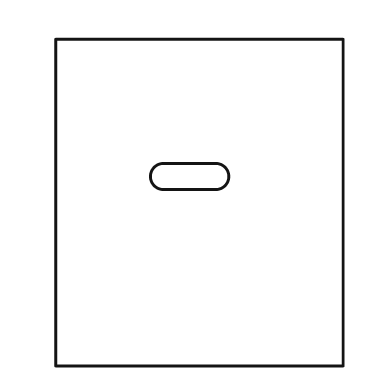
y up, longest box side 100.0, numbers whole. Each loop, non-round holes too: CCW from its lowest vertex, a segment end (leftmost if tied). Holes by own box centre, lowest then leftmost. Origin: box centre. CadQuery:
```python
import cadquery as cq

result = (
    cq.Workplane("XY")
    .moveTo(-44.0, -50.0)
    .lineTo(44.0, -50.0)
    .lineTo(44.0, 50.0)
    .lineTo(-44.0, 50.0)
    .close()
    .moveTo(-11.0, 4.0)
    .lineTo(5.0, 4.0)
    .threePointArc((9.0, 8.0), (5.0, 12.0))
    .lineTo(-11.0, 12.0)
    .threePointArc((-15.0, 8.0), (-11.0, 4.0))
    .close()
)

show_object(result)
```